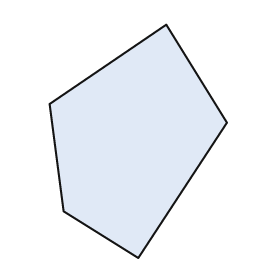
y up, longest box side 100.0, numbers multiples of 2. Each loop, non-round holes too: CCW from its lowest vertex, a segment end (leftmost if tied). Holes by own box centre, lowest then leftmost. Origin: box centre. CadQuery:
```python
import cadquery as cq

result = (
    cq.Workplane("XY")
    .moveTo(0.0, -50.0)
    .lineTo(38.0, 8.0)
    .lineTo(12.0, 50.0)
    .lineTo(-38.0, 16.0)
    .lineTo(-32.0, -30.0)
    .close()
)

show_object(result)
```